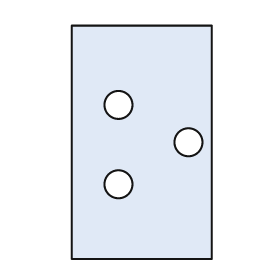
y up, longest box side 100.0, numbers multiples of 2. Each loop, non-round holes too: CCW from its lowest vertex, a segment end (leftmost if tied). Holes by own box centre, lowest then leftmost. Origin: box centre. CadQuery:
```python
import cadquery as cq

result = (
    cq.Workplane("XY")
    .moveTo(-30.0, -50.0)
    .lineTo(30.0, -50.0)
    .lineTo(30.0, 50.0)
    .lineTo(-30.0, 50.0)
    .close()
    .moveTo(-10.0, -18.0)
    .circle(6.0)
    .moveTo(20.0, 0.0)
    .circle(6.0)
    .moveTo(-10.0, 16.0)
    .circle(6.0)
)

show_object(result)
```